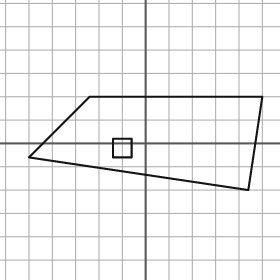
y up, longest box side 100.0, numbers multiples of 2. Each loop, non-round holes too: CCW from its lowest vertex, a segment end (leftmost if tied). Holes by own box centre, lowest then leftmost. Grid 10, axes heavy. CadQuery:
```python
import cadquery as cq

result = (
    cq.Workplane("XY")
    .moveTo(44.0, -20.0)
    .lineTo(50.0, 20.0)
    .lineTo(-24.0, 20.0)
    .lineTo(-50.0, -6.0)
    .close()
    .moveTo(-14.0, -6.0)
    .lineTo(-6.0, -6.0)
    .lineTo(-6.0, 2.0)
    .lineTo(-14.0, 2.0)
    .close()
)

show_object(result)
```